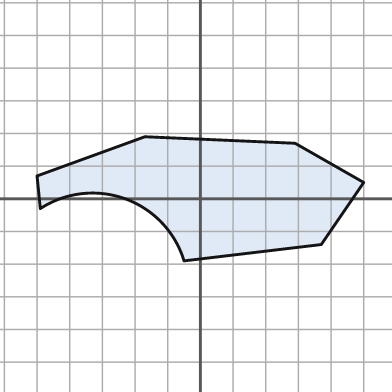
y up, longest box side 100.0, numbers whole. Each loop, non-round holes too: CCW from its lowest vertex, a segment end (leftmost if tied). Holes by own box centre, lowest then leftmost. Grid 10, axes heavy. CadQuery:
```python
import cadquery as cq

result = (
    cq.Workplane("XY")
    .moveTo(-5.0, -19.0)
    .lineTo(37.0, -14.0)
    .lineTo(50.0, 5.0)
    .lineTo(29.0, 17.0)
    .lineTo(-17.0, 19.0)
    .lineTo(-50.0, 7.0)
    .lineTo(-49.0, -3.0)
    .threePointArc((-23.0, 0.0), (-5.0, -19.0))
    .close()
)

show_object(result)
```